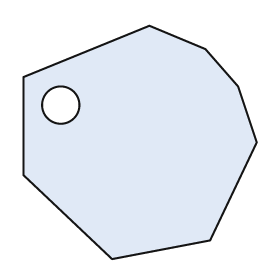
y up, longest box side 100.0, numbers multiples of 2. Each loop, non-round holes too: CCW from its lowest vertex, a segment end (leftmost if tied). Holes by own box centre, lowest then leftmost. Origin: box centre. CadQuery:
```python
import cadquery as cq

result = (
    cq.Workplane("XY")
    .moveTo(-12.0, -50.0)
    .lineTo(30.0, -42.0)
    .lineTo(50.0, 0.0)
    .lineTo(42.0, 24.0)
    .lineTo(28.0, 40.0)
    .lineTo(4.0, 50.0)
    .lineTo(-50.0, 28.0)
    .lineTo(-50.0, -14.0)
    .close()
    .moveTo(-34.0, 16.0)
    .circle(8.0)
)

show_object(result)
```